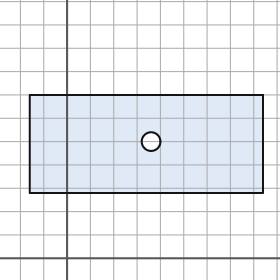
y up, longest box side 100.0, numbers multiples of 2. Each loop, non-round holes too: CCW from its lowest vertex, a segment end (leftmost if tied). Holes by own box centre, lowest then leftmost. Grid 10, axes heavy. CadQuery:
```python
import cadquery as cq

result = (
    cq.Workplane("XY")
    .moveTo(-16.0, 28.0)
    .lineTo(84.0, 28.0)
    .lineTo(84.0, 70.0)
    .lineTo(-16.0, 70.0)
    .close()
    .moveTo(36.0, 50.0)
    .circle(4.0)
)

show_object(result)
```